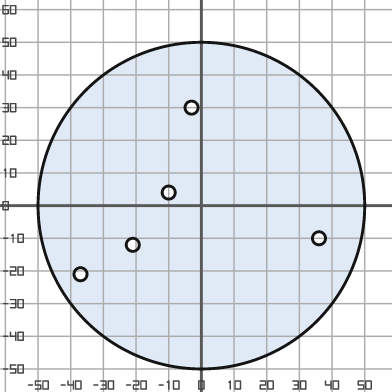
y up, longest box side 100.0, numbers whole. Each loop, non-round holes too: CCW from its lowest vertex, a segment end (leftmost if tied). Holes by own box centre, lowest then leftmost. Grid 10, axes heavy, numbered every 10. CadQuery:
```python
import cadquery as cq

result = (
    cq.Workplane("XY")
    .moveTo(0.0, 0.0)
    .circle(50.0)
    .moveTo(-37.0, -21.0)
    .circle(2.0)
    .moveTo(-21.0, -12.0)
    .circle(2.0)
    .moveTo(36.0, -10.0)
    .circle(2.0)
    .moveTo(-10.0, 4.0)
    .circle(2.0)
    .moveTo(-3.0, 30.0)
    .circle(2.0)
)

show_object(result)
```